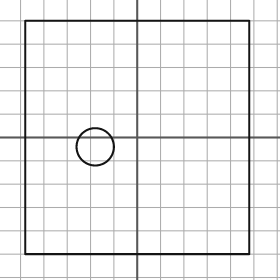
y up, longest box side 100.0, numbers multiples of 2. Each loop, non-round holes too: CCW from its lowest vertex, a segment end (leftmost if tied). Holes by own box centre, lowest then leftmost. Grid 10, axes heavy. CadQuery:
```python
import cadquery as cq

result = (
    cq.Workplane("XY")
    .moveTo(-48.0, -50.0)
    .lineTo(48.0, -50.0)
    .lineTo(48.0, 50.0)
    .lineTo(-48.0, 50.0)
    .close()
    .moveTo(-18.0, -4.0)
    .circle(8.0)
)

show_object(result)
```